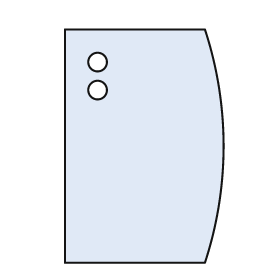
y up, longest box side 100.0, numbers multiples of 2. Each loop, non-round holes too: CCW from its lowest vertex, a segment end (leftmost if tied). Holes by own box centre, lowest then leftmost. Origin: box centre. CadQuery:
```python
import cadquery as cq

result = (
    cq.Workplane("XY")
    .moveTo(-34.0, -50.0)
    .lineTo(26.0, -50.0)
    .threePointArc((34.0, 0.0), (26.0, 50.0))
    .lineTo(-34.0, 50.0)
    .close()
    .moveTo(-20.0, 24.0)
    .circle(4.0)
    .moveTo(-20.0, 36.0)
    .circle(4.0)
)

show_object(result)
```